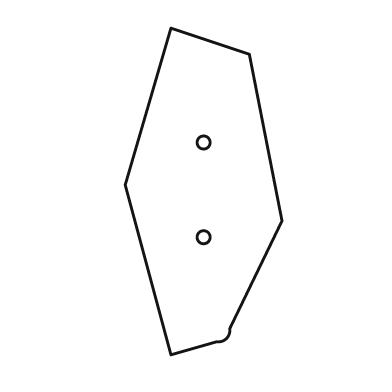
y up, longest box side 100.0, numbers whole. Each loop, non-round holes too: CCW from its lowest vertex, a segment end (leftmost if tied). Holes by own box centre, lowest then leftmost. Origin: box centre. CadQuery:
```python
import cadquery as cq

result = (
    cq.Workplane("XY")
    .moveTo(-10.0, -50.0)
    .lineTo(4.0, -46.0)
    .threePointArc((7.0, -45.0), (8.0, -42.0))
    .lineTo(24.0, -9.0)
    .lineTo(14.0, 42.0)
    .lineTo(-10.0, 50.0)
    .lineTo(-24.0, 2.0)
    .close()
    .moveTo(0.0, -14.0)
    .circle(2.0)
    .moveTo(0.0, 15.0)
    .circle(2.0)
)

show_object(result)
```